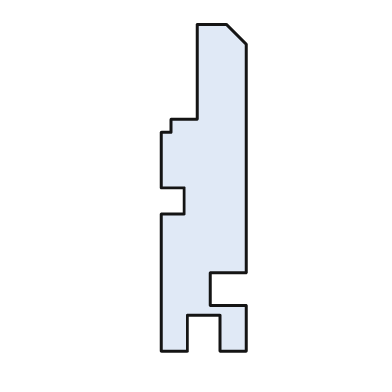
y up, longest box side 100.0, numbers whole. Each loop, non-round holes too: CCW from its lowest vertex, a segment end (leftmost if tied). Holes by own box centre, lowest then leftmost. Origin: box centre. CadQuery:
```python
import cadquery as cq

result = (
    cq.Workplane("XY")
    .moveTo(-13.0, -50.0)
    .lineTo(-5.0, -50.0)
    .lineTo(-5.0, -39.0)
    .lineTo(5.0, -39.0)
    .lineTo(5.0, -50.0)
    .lineTo(13.0, -50.0)
    .lineTo(13.0, -36.0)
    .lineTo(2.0, -36.0)
    .lineTo(2.0, -26.0)
    .lineTo(13.0, -26.0)
    .lineTo(13.0, 44.0)
    .lineTo(7.0, 50.0)
    .lineTo(-2.0, 50.0)
    .lineTo(-2.0, 21.0)
    .lineTo(-10.0, 21.0)
    .lineTo(-10.0, 17.0)
    .lineTo(-13.0, 17.0)
    .lineTo(-13.0, 0.0)
    .lineTo(-6.0, 0.0)
    .lineTo(-6.0, -8.0)
    .lineTo(-13.0, -8.0)
    .close()
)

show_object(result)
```